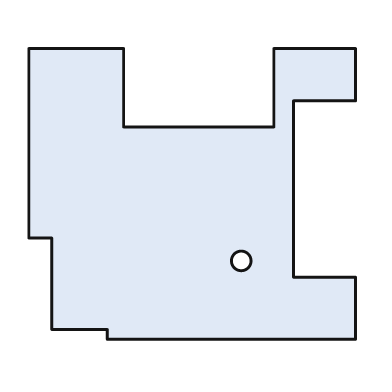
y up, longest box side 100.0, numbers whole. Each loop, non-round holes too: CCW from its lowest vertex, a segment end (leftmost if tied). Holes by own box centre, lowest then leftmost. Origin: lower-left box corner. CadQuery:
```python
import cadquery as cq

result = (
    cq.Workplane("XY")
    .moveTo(24.0, 0.0)
    .lineTo(100.0, 0.0)
    .lineTo(100.0, 19.0)
    .lineTo(81.0, 19.0)
    .lineTo(81.0, 73.0)
    .lineTo(100.0, 73.0)
    .lineTo(100.0, 89.0)
    .lineTo(75.0, 89.0)
    .lineTo(75.0, 65.0)
    .lineTo(29.0, 65.0)
    .lineTo(29.0, 89.0)
    .lineTo(0.0, 89.0)
    .lineTo(0.0, 31.0)
    .lineTo(7.0, 31.0)
    .lineTo(7.0, 3.0)
    .lineTo(24.0, 3.0)
    .close()
    .moveTo(65.0, 24.0)
    .circle(3.0)
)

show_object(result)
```